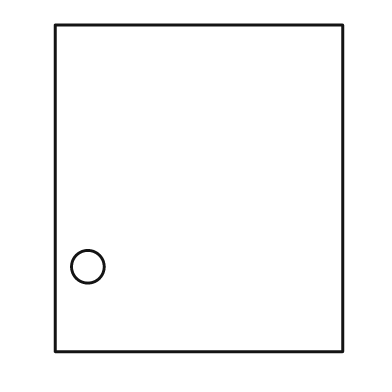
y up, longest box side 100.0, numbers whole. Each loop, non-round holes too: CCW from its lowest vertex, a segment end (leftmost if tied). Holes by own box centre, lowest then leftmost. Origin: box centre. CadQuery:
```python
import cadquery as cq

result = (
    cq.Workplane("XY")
    .moveTo(-44.0, -50.0)
    .lineTo(44.0, -50.0)
    .lineTo(44.0, 50.0)
    .lineTo(-44.0, 50.0)
    .close()
    .moveTo(-34.0, -24.0)
    .circle(5.0)
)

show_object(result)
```